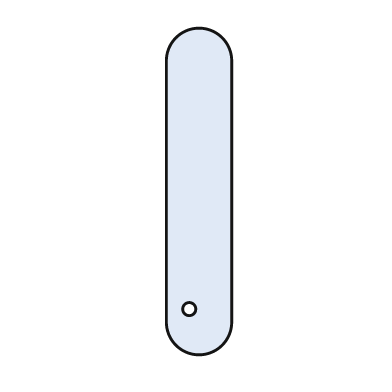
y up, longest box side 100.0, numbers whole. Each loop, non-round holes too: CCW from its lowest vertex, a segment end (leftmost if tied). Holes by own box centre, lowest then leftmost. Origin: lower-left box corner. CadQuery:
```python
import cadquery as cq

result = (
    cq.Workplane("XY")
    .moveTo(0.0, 10.0)
    .threePointArc((10.0, 0.0), (20.0, 10.0))
    .lineTo(20.0, 90.0)
    .threePointArc((10.0, 100.0), (0.0, 90.0))
    .close()
    .moveTo(7.0, 14.0)
    .circle(2.0)
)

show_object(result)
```